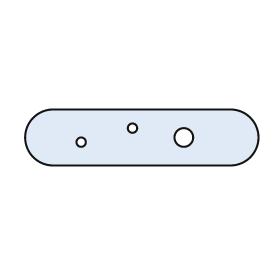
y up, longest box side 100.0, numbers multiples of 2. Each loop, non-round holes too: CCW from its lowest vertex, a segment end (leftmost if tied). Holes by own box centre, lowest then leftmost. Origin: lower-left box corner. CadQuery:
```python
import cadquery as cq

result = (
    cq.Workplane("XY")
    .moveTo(12.0, 0.0)
    .lineTo(88.0, 0.0)
    .threePointArc((100.0, 12.0), (88.0, 24.0))
    .lineTo(12.0, 24.0)
    .threePointArc((0.0, 12.0), (12.0, 0.0))
    .close()
    .moveTo(24.0, 10.0)
    .circle(2.0)
    .moveTo(68.0, 12.0)
    .circle(4.0)
    .moveTo(46.0, 16.0)
    .circle(2.0)
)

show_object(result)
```